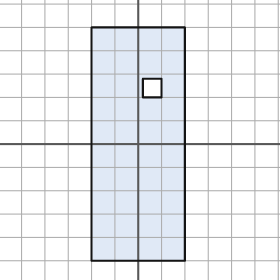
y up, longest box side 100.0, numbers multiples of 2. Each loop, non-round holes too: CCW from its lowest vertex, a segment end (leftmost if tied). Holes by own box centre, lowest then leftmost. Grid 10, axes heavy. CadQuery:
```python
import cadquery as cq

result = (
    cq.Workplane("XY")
    .moveTo(-20.0, -50.0)
    .lineTo(20.0, -50.0)
    .lineTo(20.0, 50.0)
    .lineTo(-20.0, 50.0)
    .close()
    .moveTo(2.0, 20.0)
    .lineTo(10.0, 20.0)
    .lineTo(10.0, 28.0)
    .lineTo(2.0, 28.0)
    .close()
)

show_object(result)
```